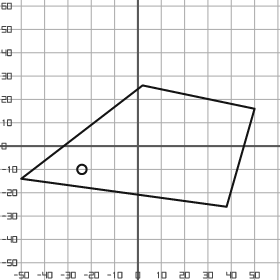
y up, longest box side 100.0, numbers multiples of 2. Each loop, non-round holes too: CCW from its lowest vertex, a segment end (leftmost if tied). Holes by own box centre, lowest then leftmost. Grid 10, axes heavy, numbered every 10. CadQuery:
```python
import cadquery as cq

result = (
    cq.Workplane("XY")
    .moveTo(38.0, -26.0)
    .lineTo(50.0, 16.0)
    .lineTo(2.0, 26.0)
    .lineTo(-50.0, -14.0)
    .close()
    .moveTo(-24.0, -10.0)
    .circle(2.0)
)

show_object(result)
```